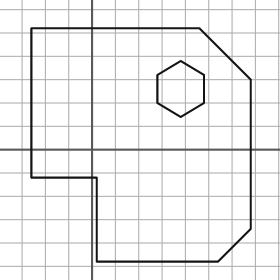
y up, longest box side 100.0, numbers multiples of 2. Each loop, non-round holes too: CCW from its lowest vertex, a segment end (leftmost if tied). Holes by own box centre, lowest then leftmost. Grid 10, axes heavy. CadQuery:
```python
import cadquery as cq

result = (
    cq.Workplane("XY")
    .moveTo(2.0, -48.0)
    .lineTo(54.0, -48.0)
    .lineTo(68.0, -34.0)
    .lineTo(68.0, 30.0)
    .lineTo(46.0, 52.0)
    .lineTo(-26.0, 52.0)
    .lineTo(-26.0, -12.0)
    .lineTo(2.0, -12.0)
    .close()
    .moveTo(38.0, 14.0)
    .lineTo(48.0, 20.0)
    .lineTo(48.0, 32.0)
    .lineTo(38.0, 38.0)
    .lineTo(28.0, 32.0)
    .lineTo(28.0, 20.0)
    .close()
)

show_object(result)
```